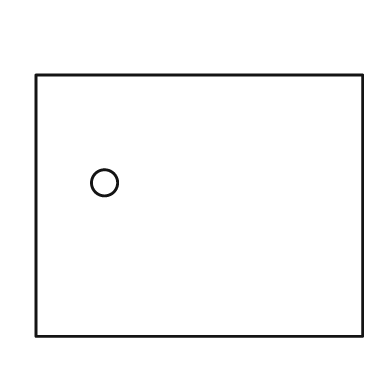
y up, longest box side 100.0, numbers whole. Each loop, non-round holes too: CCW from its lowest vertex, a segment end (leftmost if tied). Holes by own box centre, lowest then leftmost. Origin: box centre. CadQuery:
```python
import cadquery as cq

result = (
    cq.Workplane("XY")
    .moveTo(-50.0, -40.0)
    .lineTo(50.0, -40.0)
    .lineTo(50.0, 40.0)
    .lineTo(-50.0, 40.0)
    .close()
    .moveTo(-29.0, 7.0)
    .circle(4.0)
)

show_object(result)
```